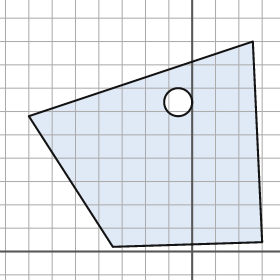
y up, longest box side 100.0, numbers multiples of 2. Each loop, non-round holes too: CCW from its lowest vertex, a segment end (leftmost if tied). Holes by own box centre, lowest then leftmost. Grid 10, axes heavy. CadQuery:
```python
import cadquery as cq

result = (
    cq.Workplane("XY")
    .moveTo(-34.0, 2.0)
    .lineTo(30.0, 4.0)
    .lineTo(26.0, 90.0)
    .lineTo(-70.0, 58.0)
    .close()
    .moveTo(-6.0, 64.0)
    .circle(6.0)
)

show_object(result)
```